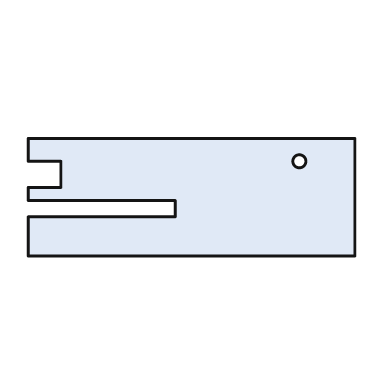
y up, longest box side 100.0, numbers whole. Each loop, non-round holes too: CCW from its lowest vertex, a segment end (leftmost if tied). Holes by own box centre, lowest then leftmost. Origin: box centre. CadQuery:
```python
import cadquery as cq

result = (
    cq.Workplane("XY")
    .moveTo(-50.0, -18.0)
    .lineTo(50.0, -18.0)
    .lineTo(50.0, 18.0)
    .lineTo(-50.0, 18.0)
    .lineTo(-50.0, 11.0)
    .lineTo(-40.0, 11.0)
    .lineTo(-40.0, 3.0)
    .lineTo(-50.0, 3.0)
    .lineTo(-50.0, -1.0)
    .lineTo(-5.0, -1.0)
    .lineTo(-5.0, -6.0)
    .lineTo(-50.0, -6.0)
    .close()
    .moveTo(33.0, 11.0)
    .circle(2.0)
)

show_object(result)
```